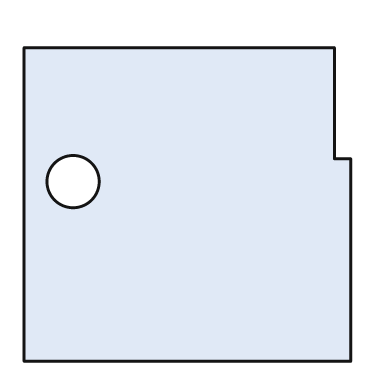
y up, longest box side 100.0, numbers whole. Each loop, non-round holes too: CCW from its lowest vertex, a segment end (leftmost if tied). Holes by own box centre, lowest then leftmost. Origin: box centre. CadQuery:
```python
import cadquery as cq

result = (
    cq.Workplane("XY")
    .moveTo(-50.0, -48.0)
    .lineTo(50.0, -48.0)
    .lineTo(50.0, 14.0)
    .lineTo(45.0, 14.0)
    .lineTo(45.0, 48.0)
    .lineTo(-50.0, 48.0)
    .close()
    .moveTo(-35.0, 7.0)
    .circle(8.0)
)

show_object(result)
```